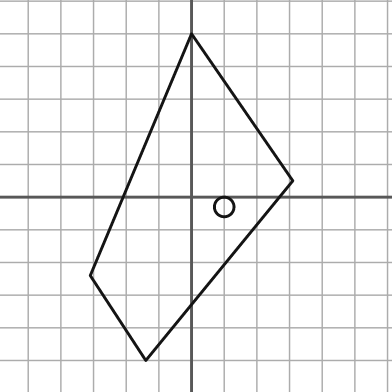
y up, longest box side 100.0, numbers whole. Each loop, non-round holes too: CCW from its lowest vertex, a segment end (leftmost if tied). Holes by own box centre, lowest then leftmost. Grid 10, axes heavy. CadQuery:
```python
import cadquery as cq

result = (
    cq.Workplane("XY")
    .moveTo(-14.0, -50.0)
    .lineTo(31.0, 5.0)
    .lineTo(0.0, 50.0)
    .lineTo(-31.0, -24.0)
    .close()
    .moveTo(10.0, -3.0)
    .circle(3.0)
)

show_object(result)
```